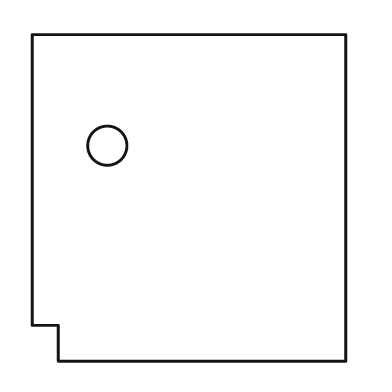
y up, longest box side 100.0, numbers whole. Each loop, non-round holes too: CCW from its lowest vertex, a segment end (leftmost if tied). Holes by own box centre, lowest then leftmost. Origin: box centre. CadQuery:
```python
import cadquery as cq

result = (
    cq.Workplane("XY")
    .moveTo(-40.0, -50.0)
    .lineTo(48.0, -50.0)
    .lineTo(48.0, 50.0)
    .lineTo(-48.0, 50.0)
    .lineTo(-48.0, -39.0)
    .lineTo(-40.0, -39.0)
    .close()
    .moveTo(-25.0, 16.0)
    .circle(6.0)
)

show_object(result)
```